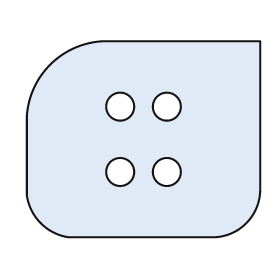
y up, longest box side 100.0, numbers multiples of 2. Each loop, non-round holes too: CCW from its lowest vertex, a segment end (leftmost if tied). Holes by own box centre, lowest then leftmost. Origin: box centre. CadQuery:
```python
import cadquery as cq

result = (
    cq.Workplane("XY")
    .moveTo(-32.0, -42.0)
    .lineTo(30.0, -42.0)
    .threePointArc((44.0, -36.0), (50.0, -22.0))
    .lineTo(50.0, 42.0)
    .lineTo(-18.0, 42.0)
    .threePointArc((-40.0, 32.0), (-50.0, 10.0))
    .lineTo(-50.0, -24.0)
    .threePointArc((-44.0, -36.0), (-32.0, -42.0))
    .close()
    .moveTo(-10.0, -14.0)
    .circle(6.0)
    .moveTo(10.0, -14.0)
    .circle(6.0)
    .moveTo(-10.0, 14.0)
    .circle(6.0)
    .moveTo(10.0, 14.0)
    .circle(6.0)
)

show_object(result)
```